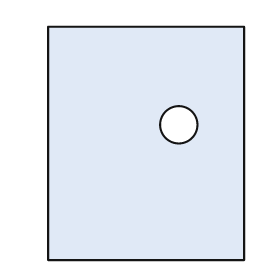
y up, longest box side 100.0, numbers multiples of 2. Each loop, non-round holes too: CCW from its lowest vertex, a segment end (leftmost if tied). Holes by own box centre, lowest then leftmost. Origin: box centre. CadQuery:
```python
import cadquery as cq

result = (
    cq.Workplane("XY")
    .moveTo(-42.0, -50.0)
    .lineTo(42.0, -50.0)
    .lineTo(42.0, 50.0)
    .lineTo(-42.0, 50.0)
    .close()
    .moveTo(14.0, 8.0)
    .circle(8.0)
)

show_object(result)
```